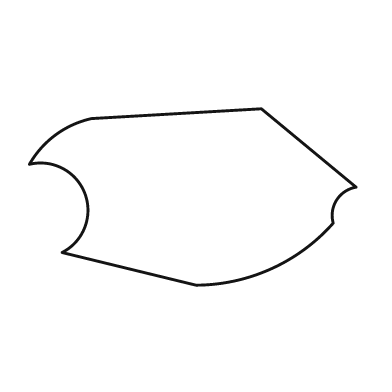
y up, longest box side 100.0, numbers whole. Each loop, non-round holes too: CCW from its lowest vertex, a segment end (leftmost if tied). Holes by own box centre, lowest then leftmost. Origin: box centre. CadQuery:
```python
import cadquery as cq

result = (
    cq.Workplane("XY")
    .moveTo(1.0, -27.0)
    .threePointArc((24.0, -22.0), (43.0, -8.0))
    .threePointArc((44.0, -1.0), (50.0, 3.0))
    .lineTo(21.0, 27.0)
    .lineTo(-31.0, 24.0)
    .threePointArc((-42.0, 19.0), (-50.0, 10.0))
    .threePointArc((-33.0, 1.0), (-40.0, -17.0))
    .close()
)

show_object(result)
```